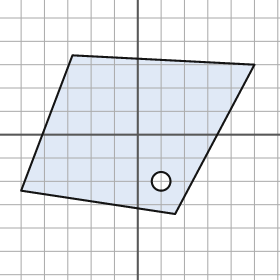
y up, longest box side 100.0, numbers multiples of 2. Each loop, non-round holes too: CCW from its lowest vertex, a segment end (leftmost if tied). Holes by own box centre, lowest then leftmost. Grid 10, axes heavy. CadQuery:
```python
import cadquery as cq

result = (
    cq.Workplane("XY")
    .moveTo(16.0, -34.0)
    .lineTo(50.0, 30.0)
    .lineTo(-28.0, 34.0)
    .lineTo(-50.0, -24.0)
    .close()
    .moveTo(10.0, -20.0)
    .circle(4.0)
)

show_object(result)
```